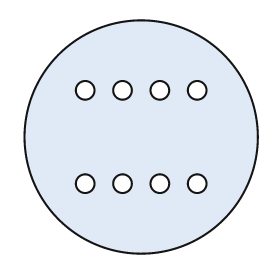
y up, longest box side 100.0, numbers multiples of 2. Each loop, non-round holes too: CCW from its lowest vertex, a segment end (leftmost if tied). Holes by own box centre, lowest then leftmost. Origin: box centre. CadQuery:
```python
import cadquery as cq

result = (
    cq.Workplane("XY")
    .moveTo(0.0, 0.0)
    .circle(50.0)
    .moveTo(-24.0, -20.0)
    .circle(4.0)
    .moveTo(-8.0, -20.0)
    .circle(4.0)
    .moveTo(8.0, -20.0)
    .circle(4.0)
    .moveTo(24.0, -20.0)
    .circle(4.0)
    .moveTo(-24.0, 20.0)
    .circle(4.0)
    .moveTo(-8.0, 20.0)
    .circle(4.0)
    .moveTo(8.0, 20.0)
    .circle(4.0)
    .moveTo(24.0, 20.0)
    .circle(4.0)
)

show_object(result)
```